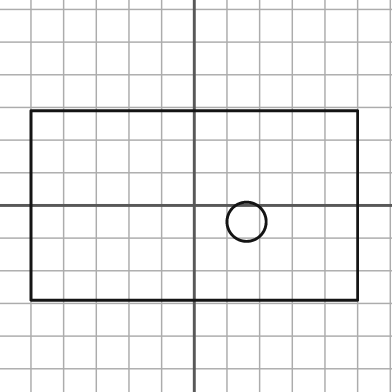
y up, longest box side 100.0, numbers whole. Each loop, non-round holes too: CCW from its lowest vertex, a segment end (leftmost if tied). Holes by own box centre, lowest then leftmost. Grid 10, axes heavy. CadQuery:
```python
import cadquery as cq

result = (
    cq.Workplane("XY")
    .moveTo(-50.0, -29.0)
    .lineTo(50.0, -29.0)
    .lineTo(50.0, 29.0)
    .lineTo(-50.0, 29.0)
    .close()
    .moveTo(16.0, -5.0)
    .circle(6.0)
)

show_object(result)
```